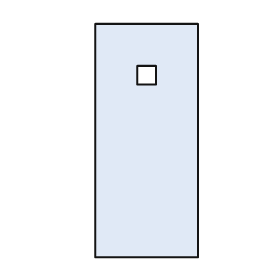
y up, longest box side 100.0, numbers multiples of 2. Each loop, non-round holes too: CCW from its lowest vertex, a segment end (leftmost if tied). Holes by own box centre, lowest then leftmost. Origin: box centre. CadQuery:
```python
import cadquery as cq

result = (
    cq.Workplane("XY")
    .moveTo(-22.0, -50.0)
    .lineTo(22.0, -50.0)
    .lineTo(22.0, 50.0)
    .lineTo(-22.0, 50.0)
    .close()
    .moveTo(-4.0, 24.0)
    .lineTo(4.0, 24.0)
    .lineTo(4.0, 32.0)
    .lineTo(-4.0, 32.0)
    .close()
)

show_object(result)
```